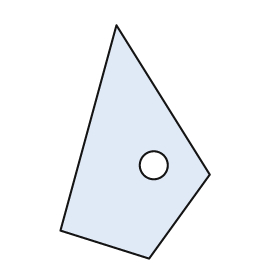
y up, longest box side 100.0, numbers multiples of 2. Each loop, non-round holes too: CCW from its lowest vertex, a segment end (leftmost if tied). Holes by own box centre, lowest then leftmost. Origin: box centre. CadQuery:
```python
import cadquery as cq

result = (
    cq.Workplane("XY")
    .moveTo(6.0, -50.0)
    .lineTo(32.0, -14.0)
    .lineTo(-8.0, 50.0)
    .lineTo(-32.0, -38.0)
    .close()
    .moveTo(8.0, -10.0)
    .circle(6.0)
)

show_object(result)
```